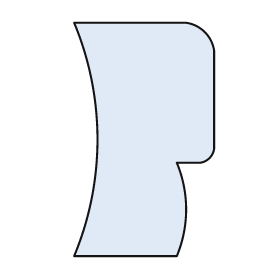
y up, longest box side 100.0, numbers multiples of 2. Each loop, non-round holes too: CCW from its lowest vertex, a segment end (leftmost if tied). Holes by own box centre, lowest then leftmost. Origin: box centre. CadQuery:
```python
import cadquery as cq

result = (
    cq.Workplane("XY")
    .moveTo(-30.0, -50.0)
    .lineTo(14.0, -50.0)
    .threePointArc((18.0, -30.0), (14.0, -10.0))
    .lineTo(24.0, -10.0)
    .threePointArc((28.0, -8.0), (30.0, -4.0))
    .lineTo(30.0, 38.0)
    .threePointArc((26.0, 46.0), (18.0, 50.0))
    .lineTo(-30.0, 50.0)
    .threePointArc((-20.0, 0.0), (-30.0, -50.0))
    .close()
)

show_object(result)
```